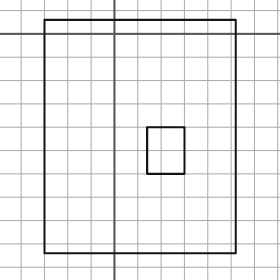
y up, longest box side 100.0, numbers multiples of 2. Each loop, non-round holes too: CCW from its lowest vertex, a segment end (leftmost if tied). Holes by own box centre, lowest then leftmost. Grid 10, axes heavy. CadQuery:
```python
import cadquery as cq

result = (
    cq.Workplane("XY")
    .moveTo(-30.0, -94.0)
    .lineTo(52.0, -94.0)
    .lineTo(52.0, 6.0)
    .lineTo(-30.0, 6.0)
    .close()
    .moveTo(14.0, -60.0)
    .lineTo(30.0, -60.0)
    .lineTo(30.0, -40.0)
    .lineTo(14.0, -40.0)
    .close()
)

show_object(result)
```